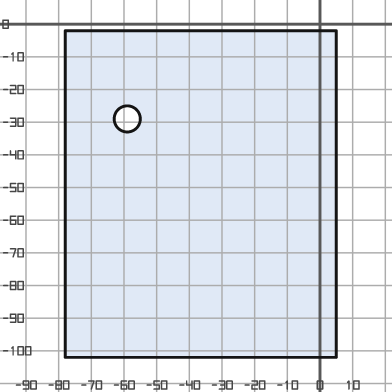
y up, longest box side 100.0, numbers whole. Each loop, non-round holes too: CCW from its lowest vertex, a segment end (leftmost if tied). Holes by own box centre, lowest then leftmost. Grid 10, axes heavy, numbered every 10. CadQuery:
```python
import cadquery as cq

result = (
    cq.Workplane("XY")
    .moveTo(-78.0, -102.0)
    .lineTo(5.0, -102.0)
    .lineTo(5.0, -2.0)
    .lineTo(-78.0, -2.0)
    .close()
    .moveTo(-59.0, -29.0)
    .circle(4.0)
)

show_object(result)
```